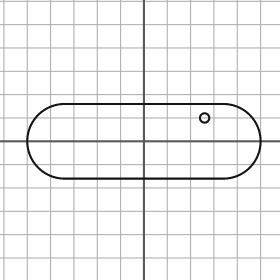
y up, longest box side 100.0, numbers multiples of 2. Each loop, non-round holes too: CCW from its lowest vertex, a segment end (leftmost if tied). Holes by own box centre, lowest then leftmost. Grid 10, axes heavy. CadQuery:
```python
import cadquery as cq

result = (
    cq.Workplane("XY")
    .moveTo(-34.0, -16.0)
    .lineTo(34.0, -16.0)
    .threePointArc((50.0, 0.0), (34.0, 16.0))
    .lineTo(-34.0, 16.0)
    .threePointArc((-50.0, 0.0), (-34.0, -16.0))
    .close()
    .moveTo(26.0, 10.0)
    .circle(2.0)
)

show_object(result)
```